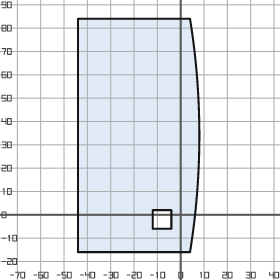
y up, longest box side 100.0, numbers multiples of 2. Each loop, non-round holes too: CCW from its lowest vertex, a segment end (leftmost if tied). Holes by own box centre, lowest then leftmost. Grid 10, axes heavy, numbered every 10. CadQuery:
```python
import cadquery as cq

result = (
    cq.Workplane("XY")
    .moveTo(-44.0, -16.0)
    .lineTo(4.0, -16.0)
    .threePointArc((8.0, 34.0), (4.0, 84.0))
    .lineTo(-44.0, 84.0)
    .close()
    .moveTo(-12.0, -6.0)
    .lineTo(-4.0, -6.0)
    .lineTo(-4.0, 2.0)
    .lineTo(-12.0, 2.0)
    .close()
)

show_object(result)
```